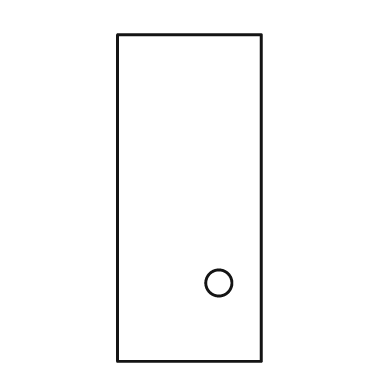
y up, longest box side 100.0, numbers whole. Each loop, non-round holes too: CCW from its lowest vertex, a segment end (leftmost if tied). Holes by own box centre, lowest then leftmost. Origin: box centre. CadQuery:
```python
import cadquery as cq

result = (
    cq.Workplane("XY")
    .moveTo(-22.0, -50.0)
    .lineTo(22.0, -50.0)
    .lineTo(22.0, 50.0)
    .lineTo(-22.0, 50.0)
    .close()
    .moveTo(9.0, -26.0)
    .circle(4.0)
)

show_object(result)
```